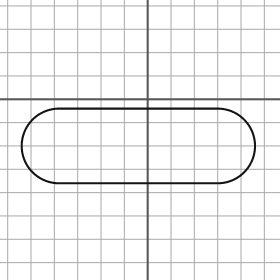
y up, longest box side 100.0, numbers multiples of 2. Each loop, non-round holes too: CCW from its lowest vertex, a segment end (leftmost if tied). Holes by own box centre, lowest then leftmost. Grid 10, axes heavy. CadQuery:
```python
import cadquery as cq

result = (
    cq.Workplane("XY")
    .moveTo(-38.0, -36.0)
    .lineTo(30.0, -36.0)
    .threePointArc((46.0, -20.0), (30.0, -4.0))
    .lineTo(-38.0, -4.0)
    .threePointArc((-54.0, -20.0), (-38.0, -36.0))
    .close()
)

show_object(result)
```